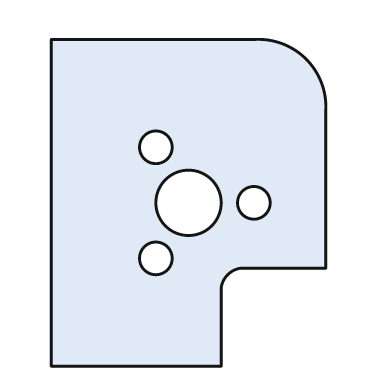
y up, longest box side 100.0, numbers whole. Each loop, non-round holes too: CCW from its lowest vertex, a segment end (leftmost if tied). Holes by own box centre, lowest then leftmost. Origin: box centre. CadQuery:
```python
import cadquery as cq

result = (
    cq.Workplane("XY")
    .moveTo(-42.0, -50.0)
    .lineTo(10.0, -50.0)
    .lineTo(10.0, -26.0)
    .threePointArc((12.0, -22.0), (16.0, -20.0))
    .lineTo(42.0, -20.0)
    .lineTo(42.0, 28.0)
    .threePointArc((36.0, 44.0), (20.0, 50.0))
    .lineTo(-42.0, 50.0)
    .close()
    .moveTo(-10.0, -17.0)
    .circle(5.0)
    .moveTo(0.0, 0.0)
    .circle(10.0)
    .moveTo(20.0, 0.0)
    .circle(5.0)
    .moveTo(-10.0, 17.0)
    .circle(5.0)
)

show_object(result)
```